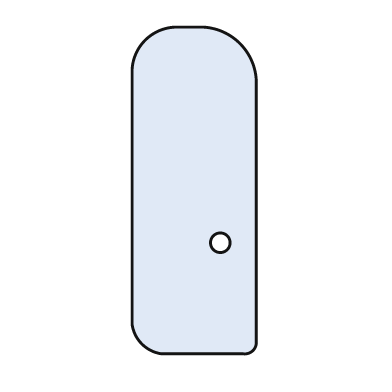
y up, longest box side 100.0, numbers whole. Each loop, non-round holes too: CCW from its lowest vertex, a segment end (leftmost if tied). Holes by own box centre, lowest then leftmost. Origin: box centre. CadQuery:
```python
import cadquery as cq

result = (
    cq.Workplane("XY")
    .moveTo(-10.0, -50.0)
    .lineTo(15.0, -50.0)
    .threePointArc((18.0, -49.0), (19.0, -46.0))
    .lineTo(19.0, 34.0)
    .threePointArc((14.0, 45.0), (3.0, 50.0))
    .lineTo(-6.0, 50.0)
    .threePointArc((-15.0, 46.0), (-19.0, 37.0))
    .lineTo(-19.0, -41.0)
    .threePointArc((-16.0, -47.0), (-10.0, -50.0))
    .close()
    .moveTo(8.0, -16.0)
    .circle(3.0)
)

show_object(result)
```